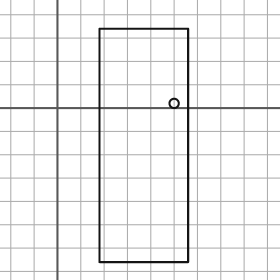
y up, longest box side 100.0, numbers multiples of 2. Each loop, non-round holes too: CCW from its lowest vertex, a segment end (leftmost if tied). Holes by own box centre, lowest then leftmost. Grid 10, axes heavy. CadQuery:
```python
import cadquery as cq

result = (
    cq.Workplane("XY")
    .moveTo(18.0, -66.0)
    .lineTo(56.0, -66.0)
    .lineTo(56.0, 34.0)
    .lineTo(18.0, 34.0)
    .close()
    .moveTo(50.0, 2.0)
    .circle(2.0)
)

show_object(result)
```